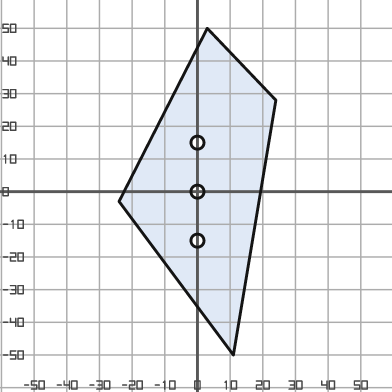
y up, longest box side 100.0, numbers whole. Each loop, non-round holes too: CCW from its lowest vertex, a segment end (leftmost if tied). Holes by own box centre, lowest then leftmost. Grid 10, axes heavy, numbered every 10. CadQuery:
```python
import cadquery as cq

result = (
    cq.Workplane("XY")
    .moveTo(11.0, -50.0)
    .lineTo(24.0, 28.0)
    .lineTo(3.0, 50.0)
    .lineTo(-24.0, -3.0)
    .close()
    .moveTo(0.0, -15.0)
    .circle(2.0)
    .moveTo(0.0, 0.0)
    .circle(2.0)
    .moveTo(0.0, 15.0)
    .circle(2.0)
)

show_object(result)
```